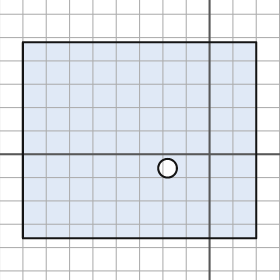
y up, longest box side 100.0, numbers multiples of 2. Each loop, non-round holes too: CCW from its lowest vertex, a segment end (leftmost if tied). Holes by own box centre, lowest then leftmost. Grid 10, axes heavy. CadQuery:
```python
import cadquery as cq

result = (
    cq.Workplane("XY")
    .moveTo(-80.0, -36.0)
    .lineTo(20.0, -36.0)
    .lineTo(20.0, 48.0)
    .lineTo(-80.0, 48.0)
    .close()
    .moveTo(-18.0, -6.0)
    .circle(4.0)
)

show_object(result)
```